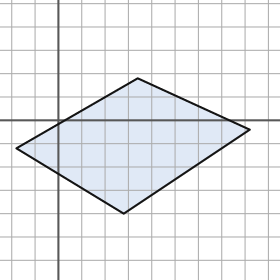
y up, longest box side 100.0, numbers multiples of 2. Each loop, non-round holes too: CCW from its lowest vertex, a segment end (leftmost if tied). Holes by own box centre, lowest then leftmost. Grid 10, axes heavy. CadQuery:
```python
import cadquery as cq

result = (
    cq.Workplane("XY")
    .moveTo(28.0, -40.0)
    .lineTo(82.0, -4.0)
    .lineTo(34.0, 18.0)
    .lineTo(-18.0, -12.0)
    .close()
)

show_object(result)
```